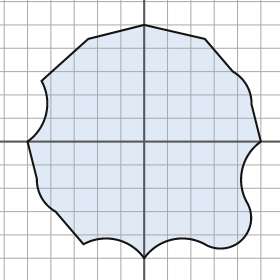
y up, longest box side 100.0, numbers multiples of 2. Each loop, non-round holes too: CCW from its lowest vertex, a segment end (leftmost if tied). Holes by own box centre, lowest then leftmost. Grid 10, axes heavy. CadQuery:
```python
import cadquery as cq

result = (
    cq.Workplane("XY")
    .moveTo(0.0, -50.0)
    .threePointArc((12.0, -42.0), (26.0, -44.0))
    .threePointArc((42.0, -42.0), (44.0, -26.0))
    .threePointArc((42.0, -12.0), (50.0, 0.0))
    .lineTo(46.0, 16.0)
    .threePointArc((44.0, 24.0), (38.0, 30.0))
    .lineTo(26.0, 44.0)
    .lineTo(0.0, 50.0)
    .lineTo(-24.0, 44.0)
    .lineTo(-44.0, 26.0)
    .threePointArc((-42.0, 12.0), (-50.0, 0.0))
    .lineTo(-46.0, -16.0)
    .threePointArc((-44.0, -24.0), (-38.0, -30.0))
    .lineTo(-26.0, -44.0)
    .threePointArc((-12.0, -42.0), (0.0, -50.0))
    .close()
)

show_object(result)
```